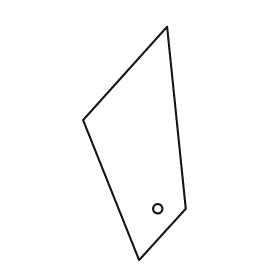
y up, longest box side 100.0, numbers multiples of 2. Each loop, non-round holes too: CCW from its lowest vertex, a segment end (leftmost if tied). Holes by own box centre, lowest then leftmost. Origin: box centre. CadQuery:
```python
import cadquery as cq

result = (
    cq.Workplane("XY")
    .moveTo(2.0, -50.0)
    .lineTo(22.0, -28.0)
    .lineTo(14.0, 50.0)
    .lineTo(-22.0, 10.0)
    .close()
    .moveTo(10.0, -28.0)
    .circle(2.0)
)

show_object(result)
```